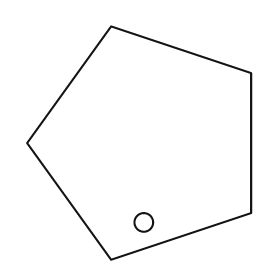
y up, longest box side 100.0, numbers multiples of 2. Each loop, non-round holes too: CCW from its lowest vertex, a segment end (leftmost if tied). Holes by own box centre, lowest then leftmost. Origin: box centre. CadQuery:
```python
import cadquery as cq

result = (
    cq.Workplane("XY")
    .moveTo(-12.0, -50.0)
    .lineTo(48.0, -30.0)
    .lineTo(48.0, 30.0)
    .lineTo(-12.0, 50.0)
    .lineTo(-48.0, 0.0)
    .close()
    .moveTo(2.0, -34.0)
    .circle(4.0)
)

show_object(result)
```